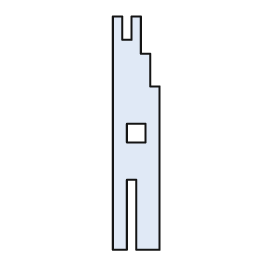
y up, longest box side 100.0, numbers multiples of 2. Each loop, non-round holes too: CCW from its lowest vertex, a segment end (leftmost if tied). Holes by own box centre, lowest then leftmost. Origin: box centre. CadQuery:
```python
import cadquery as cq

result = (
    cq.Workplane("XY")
    .moveTo(-10.0, -50.0)
    .lineTo(-4.0, -50.0)
    .lineTo(-4.0, -20.0)
    .lineTo(0.0, -20.0)
    .lineTo(0.0, -50.0)
    .lineTo(10.0, -50.0)
    .lineTo(10.0, 20.0)
    .lineTo(6.0, 20.0)
    .lineTo(6.0, 34.0)
    .lineTo(2.0, 34.0)
    .lineTo(2.0, 50.0)
    .lineTo(-2.0, 50.0)
    .lineTo(-2.0, 40.0)
    .lineTo(-6.0, 40.0)
    .lineTo(-6.0, 50.0)
    .lineTo(-10.0, 50.0)
    .close()
    .moveTo(-4.0, -4.0)
    .lineTo(4.0, -4.0)
    .lineTo(4.0, 4.0)
    .lineTo(-4.0, 4.0)
    .close()
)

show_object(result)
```